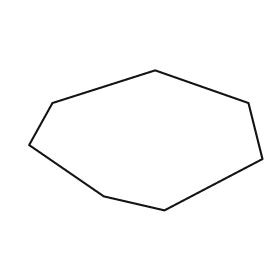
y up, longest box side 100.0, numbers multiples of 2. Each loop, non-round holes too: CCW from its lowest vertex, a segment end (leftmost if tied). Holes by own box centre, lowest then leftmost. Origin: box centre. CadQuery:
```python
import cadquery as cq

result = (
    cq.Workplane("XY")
    .moveTo(8.0, -30.0)
    .lineTo(50.0, -8.0)
    .lineTo(44.0, 16.0)
    .lineTo(4.0, 30.0)
    .lineTo(-40.0, 16.0)
    .lineTo(-50.0, -2.0)
    .lineTo(-18.0, -24.0)
    .close()
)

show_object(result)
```